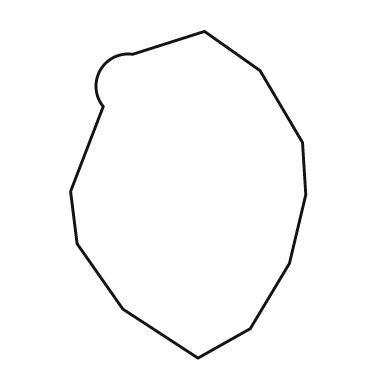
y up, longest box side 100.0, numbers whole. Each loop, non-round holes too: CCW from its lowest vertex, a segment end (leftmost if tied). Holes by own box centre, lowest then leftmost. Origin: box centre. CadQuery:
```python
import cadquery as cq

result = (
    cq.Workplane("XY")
    .moveTo(3.0, -50.0)
    .lineTo(19.0, -41.0)
    .lineTo(31.0, -21.0)
    .lineTo(36.0, 0.0)
    .lineTo(35.0, 16.0)
    .lineTo(22.0, 38.0)
    .lineTo(5.0, 50.0)
    .lineTo(-17.0, 43.0)
    .threePointArc((-27.0, 38.0), (-26.0, 27.0))
    .lineTo(-36.0, 1.0)
    .lineTo(-34.0, -15.0)
    .lineTo(-20.0, -35.0)
    .close()
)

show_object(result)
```